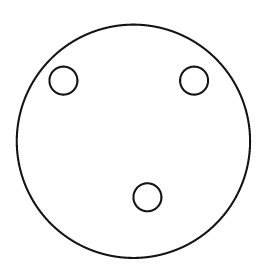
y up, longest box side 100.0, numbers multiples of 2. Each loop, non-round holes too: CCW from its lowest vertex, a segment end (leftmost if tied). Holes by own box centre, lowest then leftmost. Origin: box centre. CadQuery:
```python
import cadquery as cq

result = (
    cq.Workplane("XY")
    .moveTo(0.0, 0.0)
    .circle(50.0)
    .moveTo(6.0, -24.0)
    .circle(6.0)
    .moveTo(-30.0, 26.0)
    .circle(6.0)
    .moveTo(26.0, 26.0)
    .circle(6.0)
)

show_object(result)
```